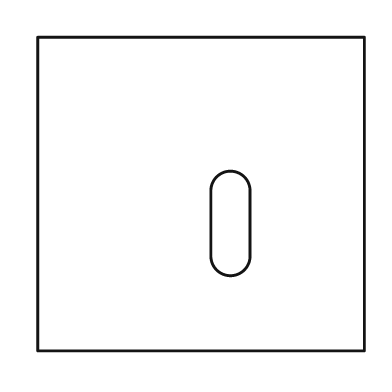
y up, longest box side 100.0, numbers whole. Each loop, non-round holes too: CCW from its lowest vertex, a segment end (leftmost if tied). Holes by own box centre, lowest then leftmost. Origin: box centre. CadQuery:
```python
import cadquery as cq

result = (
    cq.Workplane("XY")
    .moveTo(-50.0, -48.0)
    .lineTo(50.0, -48.0)
    .lineTo(50.0, 48.0)
    .lineTo(-50.0, 48.0)
    .close()
    .moveTo(3.0, -19.0)
    .threePointArc((9.0, -25.0), (15.0, -19.0))
    .lineTo(15.0, 1.0)
    .threePointArc((9.0, 7.0), (3.0, 1.0))
    .close()
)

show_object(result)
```